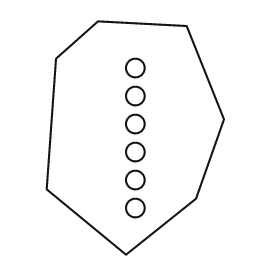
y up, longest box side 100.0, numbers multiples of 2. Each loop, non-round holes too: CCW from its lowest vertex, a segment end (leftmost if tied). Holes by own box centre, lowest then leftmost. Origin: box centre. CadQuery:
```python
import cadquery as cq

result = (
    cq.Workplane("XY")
    .moveTo(-4.0, -50.0)
    .lineTo(26.0, -26.0)
    .lineTo(38.0, 8.0)
    .lineTo(22.0, 48.0)
    .lineTo(-16.0, 50.0)
    .lineTo(-34.0, 34.0)
    .lineTo(-38.0, -22.0)
    .close()
    .moveTo(0.0, -30.0)
    .circle(4.0)
    .moveTo(0.0, -18.0)
    .circle(4.0)
    .moveTo(0.0, -6.0)
    .circle(4.0)
    .moveTo(0.0, 6.0)
    .circle(4.0)
    .moveTo(0.0, 18.0)
    .circle(4.0)
    .moveTo(0.0, 30.0)
    .circle(4.0)
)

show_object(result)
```